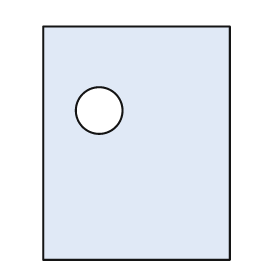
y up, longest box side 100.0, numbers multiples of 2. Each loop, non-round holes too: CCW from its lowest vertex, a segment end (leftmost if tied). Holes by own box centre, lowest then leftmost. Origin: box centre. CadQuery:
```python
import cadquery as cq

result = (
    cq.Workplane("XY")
    .moveTo(-40.0, -50.0)
    .lineTo(40.0, -50.0)
    .lineTo(40.0, 50.0)
    .lineTo(-40.0, 50.0)
    .close()
    .moveTo(-16.0, 14.0)
    .circle(10.0)
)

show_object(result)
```